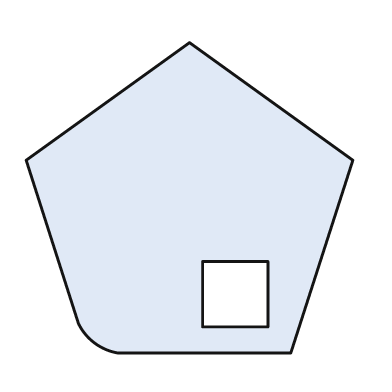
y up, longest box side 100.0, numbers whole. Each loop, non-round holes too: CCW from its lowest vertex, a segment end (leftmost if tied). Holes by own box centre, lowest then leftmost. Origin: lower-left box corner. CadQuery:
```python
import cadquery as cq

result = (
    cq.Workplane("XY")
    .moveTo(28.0, 0.0)
    .lineTo(81.0, 0.0)
    .lineTo(100.0, 59.0)
    .lineTo(50.0, 95.0)
    .lineTo(0.0, 59.0)
    .lineTo(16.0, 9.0)
    .threePointArc((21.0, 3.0), (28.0, 0.0))
    .close()
    .moveTo(54.0, 8.0)
    .lineTo(74.0, 8.0)
    .lineTo(74.0, 28.0)
    .lineTo(54.0, 28.0)
    .close()
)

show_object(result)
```